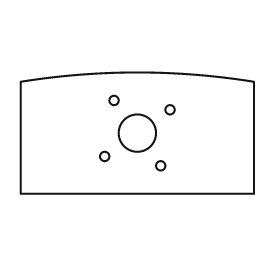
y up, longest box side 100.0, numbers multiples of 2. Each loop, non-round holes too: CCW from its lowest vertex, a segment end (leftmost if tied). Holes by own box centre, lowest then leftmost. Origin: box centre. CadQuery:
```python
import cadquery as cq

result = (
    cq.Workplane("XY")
    .moveTo(-50.0, -26.0)
    .lineTo(50.0, -26.0)
    .lineTo(50.0, 22.0)
    .threePointArc((0.0, 26.0), (-50.0, 22.0))
    .close()
    .moveTo(10.0, -14.0)
    .circle(2.0)
    .moveTo(-14.0, -10.0)
    .circle(2.0)
    .moveTo(0.0, 0.0)
    .circle(8.0)
    .moveTo(14.0, 10.0)
    .circle(2.0)
    .moveTo(-10.0, 14.0)
    .circle(2.0)
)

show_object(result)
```